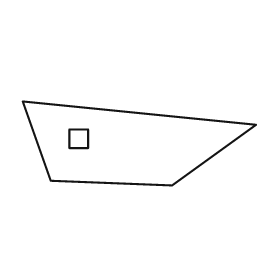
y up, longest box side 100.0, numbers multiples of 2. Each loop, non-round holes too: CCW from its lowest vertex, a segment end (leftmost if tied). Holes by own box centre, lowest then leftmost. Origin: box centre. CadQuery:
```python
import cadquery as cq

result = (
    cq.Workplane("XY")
    .moveTo(14.0, -18.0)
    .lineTo(50.0, 8.0)
    .lineTo(-50.0, 18.0)
    .lineTo(-38.0, -16.0)
    .close()
    .moveTo(-30.0, -2.0)
    .lineTo(-22.0, -2.0)
    .lineTo(-22.0, 6.0)
    .lineTo(-30.0, 6.0)
    .close()
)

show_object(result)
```